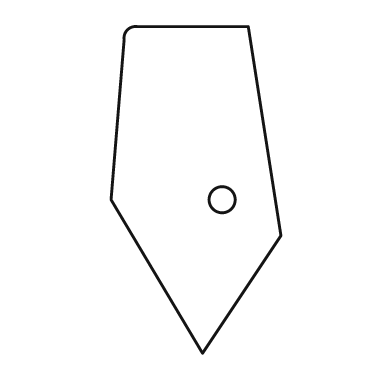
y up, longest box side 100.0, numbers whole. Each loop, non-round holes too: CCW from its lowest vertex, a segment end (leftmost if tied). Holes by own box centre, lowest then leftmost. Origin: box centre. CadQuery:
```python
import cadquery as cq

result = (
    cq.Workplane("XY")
    .moveTo(2.0, -50.0)
    .lineTo(26.0, -14.0)
    .lineTo(16.0, 50.0)
    .lineTo(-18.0, 50.0)
    .threePointArc((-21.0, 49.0), (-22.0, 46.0))
    .lineTo(-26.0, -3.0)
    .close()
    .moveTo(8.0, -3.0)
    .circle(4.0)
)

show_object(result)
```